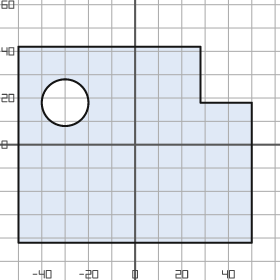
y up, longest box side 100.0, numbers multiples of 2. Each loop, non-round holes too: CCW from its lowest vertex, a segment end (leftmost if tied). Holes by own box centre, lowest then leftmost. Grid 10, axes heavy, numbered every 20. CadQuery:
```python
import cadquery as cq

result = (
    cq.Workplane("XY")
    .moveTo(-50.0, -42.0)
    .lineTo(50.0, -42.0)
    .lineTo(50.0, 18.0)
    .lineTo(28.0, 18.0)
    .lineTo(28.0, 42.0)
    .lineTo(-50.0, 42.0)
    .close()
    .moveTo(-30.0, 18.0)
    .circle(10.0)
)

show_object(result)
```